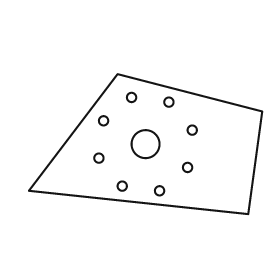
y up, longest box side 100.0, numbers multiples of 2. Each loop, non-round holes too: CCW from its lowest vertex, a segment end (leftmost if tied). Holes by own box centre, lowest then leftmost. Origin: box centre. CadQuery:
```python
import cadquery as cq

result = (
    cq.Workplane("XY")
    .moveTo(44.0, -30.0)
    .lineTo(50.0, 14.0)
    .lineTo(-12.0, 30.0)
    .lineTo(-50.0, -20.0)
    .close()
    .moveTo(6.0, -20.0)
    .circle(2.0)
    .moveTo(-10.0, -18.0)
    .circle(2.0)
    .moveTo(18.0, -10.0)
    .circle(2.0)
    .moveTo(-20.0, -6.0)
    .circle(2.0)
    .moveTo(0.0, 0.0)
    .circle(6.0)
    .moveTo(20.0, 6.0)
    .circle(2.0)
    .moveTo(-18.0, 10.0)
    .circle(2.0)
    .moveTo(10.0, 18.0)
    .circle(2.0)
    .moveTo(-6.0, 20.0)
    .circle(2.0)
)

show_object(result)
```